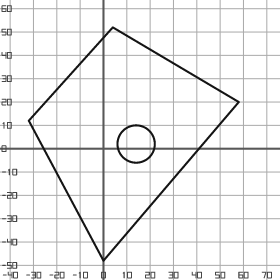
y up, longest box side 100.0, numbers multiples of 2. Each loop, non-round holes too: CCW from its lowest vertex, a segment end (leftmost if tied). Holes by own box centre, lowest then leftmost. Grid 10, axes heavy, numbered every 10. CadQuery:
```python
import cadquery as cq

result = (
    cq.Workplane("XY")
    .moveTo(0.0, -48.0)
    .lineTo(58.0, 20.0)
    .lineTo(4.0, 52.0)
    .lineTo(-32.0, 12.0)
    .close()
    .moveTo(14.0, 2.0)
    .circle(8.0)
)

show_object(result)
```